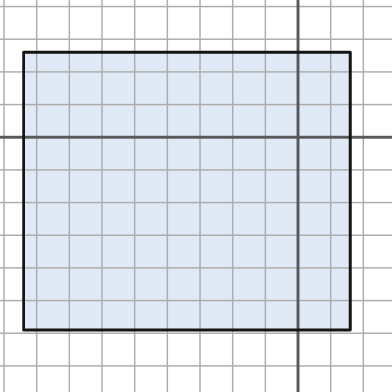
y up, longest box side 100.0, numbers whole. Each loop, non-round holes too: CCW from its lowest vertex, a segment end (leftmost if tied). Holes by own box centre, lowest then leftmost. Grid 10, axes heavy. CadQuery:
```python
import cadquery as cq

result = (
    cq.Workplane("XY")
    .moveTo(-84.0, -59.0)
    .lineTo(16.0, -59.0)
    .lineTo(16.0, 26.0)
    .lineTo(-84.0, 26.0)
    .close()
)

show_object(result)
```